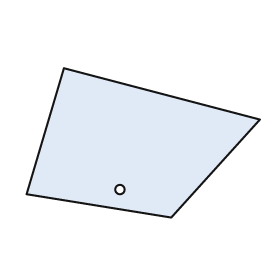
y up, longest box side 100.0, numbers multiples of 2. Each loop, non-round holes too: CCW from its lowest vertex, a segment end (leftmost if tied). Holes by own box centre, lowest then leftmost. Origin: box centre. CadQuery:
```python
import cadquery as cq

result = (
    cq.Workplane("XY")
    .moveTo(12.0, -32.0)
    .lineTo(50.0, 10.0)
    .lineTo(-34.0, 32.0)
    .lineTo(-50.0, -22.0)
    .close()
    .moveTo(-10.0, -20.0)
    .circle(2.0)
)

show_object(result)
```